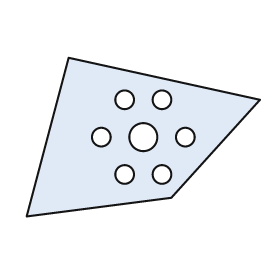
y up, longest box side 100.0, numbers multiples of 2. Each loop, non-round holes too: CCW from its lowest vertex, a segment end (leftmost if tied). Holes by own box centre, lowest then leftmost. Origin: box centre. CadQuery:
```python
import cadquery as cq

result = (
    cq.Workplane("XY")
    .moveTo(-50.0, -34.0)
    .lineTo(12.0, -26.0)
    .lineTo(50.0, 16.0)
    .lineTo(-32.0, 34.0)
    .close()
    .moveTo(-8.0, -16.0)
    .circle(4.0)
    .moveTo(8.0, -16.0)
    .circle(4.0)
    .moveTo(-18.0, 0.0)
    .circle(4.0)
    .moveTo(0.0, 0.0)
    .circle(6.0)
    .moveTo(18.0, 0.0)
    .circle(4.0)
    .moveTo(-8.0, 16.0)
    .circle(4.0)
    .moveTo(8.0, 16.0)
    .circle(4.0)
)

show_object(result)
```